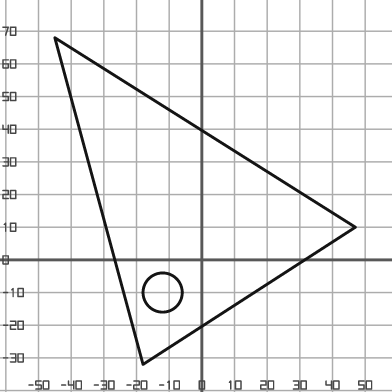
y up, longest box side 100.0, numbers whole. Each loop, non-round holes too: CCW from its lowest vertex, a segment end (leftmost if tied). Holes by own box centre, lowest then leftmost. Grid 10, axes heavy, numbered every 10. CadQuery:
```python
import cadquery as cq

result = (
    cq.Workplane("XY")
    .moveTo(-18.0, -32.0)
    .lineTo(47.0, 10.0)
    .lineTo(-45.0, 68.0)
    .close()
    .moveTo(-12.0, -10.0)
    .circle(6.0)
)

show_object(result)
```